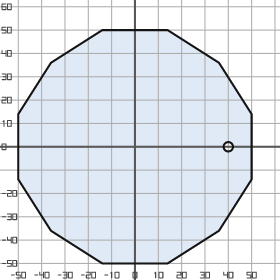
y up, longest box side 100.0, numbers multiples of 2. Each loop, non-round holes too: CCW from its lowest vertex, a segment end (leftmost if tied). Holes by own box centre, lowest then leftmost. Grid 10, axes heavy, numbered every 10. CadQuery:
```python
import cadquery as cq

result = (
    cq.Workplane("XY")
    .moveTo(-14.0, -50.0)
    .lineTo(14.0, -50.0)
    .lineTo(36.0, -36.0)
    .lineTo(50.0, -14.0)
    .lineTo(50.0, 14.0)
    .lineTo(36.0, 36.0)
    .lineTo(14.0, 50.0)
    .lineTo(-14.0, 50.0)
    .lineTo(-36.0, 36.0)
    .lineTo(-50.0, 14.0)
    .lineTo(-50.0, -14.0)
    .lineTo(-36.0, -36.0)
    .close()
    .moveTo(40.0, 0.0)
    .circle(2.0)
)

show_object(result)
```